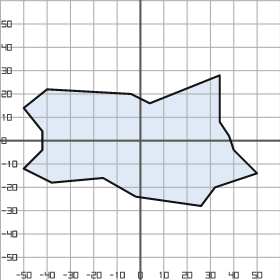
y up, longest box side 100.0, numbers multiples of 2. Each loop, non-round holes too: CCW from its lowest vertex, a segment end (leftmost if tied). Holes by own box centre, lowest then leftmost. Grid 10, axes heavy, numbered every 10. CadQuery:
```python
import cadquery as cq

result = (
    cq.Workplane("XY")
    .moveTo(26.0, -28.0)
    .lineTo(32.0, -20.0)
    .lineTo(50.0, -14.0)
    .lineTo(40.0, -4.0)
    .lineTo(38.0, 2.0)
    .lineTo(34.0, 8.0)
    .lineTo(34.0, 28.0)
    .lineTo(4.0, 16.0)
    .lineTo(-4.0, 20.0)
    .lineTo(-40.0, 22.0)
    .lineTo(-50.0, 14.0)
    .lineTo(-42.0, 4.0)
    .lineTo(-42.0, -4.0)
    .lineTo(-50.0, -12.0)
    .lineTo(-38.0, -18.0)
    .lineTo(-16.0, -16.0)
    .lineTo(-2.0, -24.0)
    .close()
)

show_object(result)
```